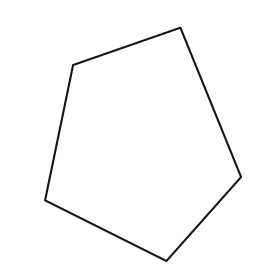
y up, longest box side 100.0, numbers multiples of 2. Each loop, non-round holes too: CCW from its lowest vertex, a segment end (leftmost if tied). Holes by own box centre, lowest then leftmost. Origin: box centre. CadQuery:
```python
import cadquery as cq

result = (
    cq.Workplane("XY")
    .moveTo(10.0, -50.0)
    .lineTo(42.0, -14.0)
    .lineTo(16.0, 50.0)
    .lineTo(-30.0, 34.0)
    .lineTo(-42.0, -24.0)
    .close()
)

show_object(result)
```